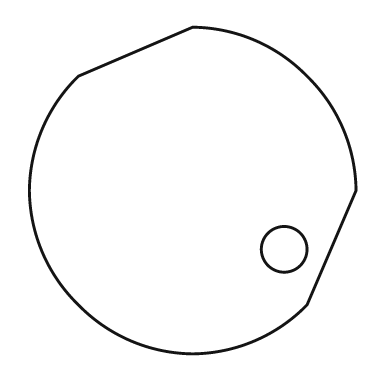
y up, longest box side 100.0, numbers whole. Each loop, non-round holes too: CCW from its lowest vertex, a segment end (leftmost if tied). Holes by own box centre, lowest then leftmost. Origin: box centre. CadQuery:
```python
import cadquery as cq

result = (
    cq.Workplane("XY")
    .moveTo(0.0, -50.0)
    .threePointArc((19.0, -46.0), (35.0, -35.0))
    .lineTo(50.0, 0.0)
    .threePointArc((46.0, 19.0), (35.0, 35.0))
    .threePointArc((19.0, 46.0), (0.0, 50.0))
    .lineTo(-35.0, 35.0)
    .threePointArc((-46.0, 19.0), (-50.0, 0.0))
    .threePointArc((-46.0, -19.0), (-35.0, -35.0))
    .threePointArc((-19.0, -46.0), (0.0, -50.0))
    .close()
    .moveTo(28.0, -18.0)
    .circle(7.0)
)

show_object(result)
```